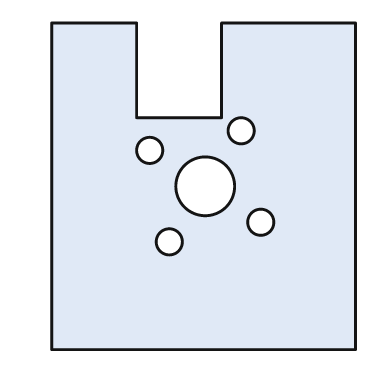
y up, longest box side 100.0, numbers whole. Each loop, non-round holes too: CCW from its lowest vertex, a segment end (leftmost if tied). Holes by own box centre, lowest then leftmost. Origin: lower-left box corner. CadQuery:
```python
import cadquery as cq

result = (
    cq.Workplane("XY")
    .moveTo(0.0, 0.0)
    .lineTo(93.0, 0.0)
    .lineTo(93.0, 100.0)
    .lineTo(52.0, 100.0)
    .lineTo(52.0, 71.0)
    .lineTo(26.0, 71.0)
    .lineTo(26.0, 100.0)
    .lineTo(0.0, 100.0)
    .close()
    .moveTo(36.0, 33.0)
    .circle(4.0)
    .moveTo(64.0, 39.0)
    .circle(4.0)
    .moveTo(47.0, 50.0)
    .circle(9.0)
    .moveTo(30.0, 61.0)
    .circle(4.0)
    .moveTo(58.0, 67.0)
    .circle(4.0)
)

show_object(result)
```